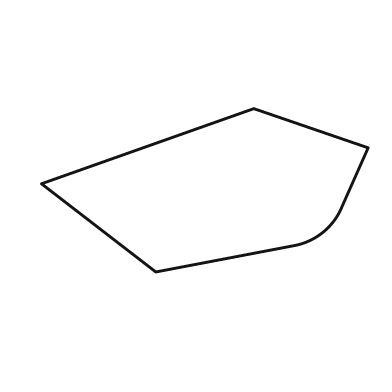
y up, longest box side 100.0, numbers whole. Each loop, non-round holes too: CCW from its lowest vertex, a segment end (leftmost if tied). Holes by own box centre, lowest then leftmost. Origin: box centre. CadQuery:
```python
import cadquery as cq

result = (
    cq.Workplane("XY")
    .moveTo(-15.0, -25.0)
    .lineTo(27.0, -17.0)
    .threePointArc((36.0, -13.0), (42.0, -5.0))
    .lineTo(50.0, 13.0)
    .lineTo(15.0, 25.0)
    .lineTo(-50.0, 2.0)
    .close()
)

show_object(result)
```